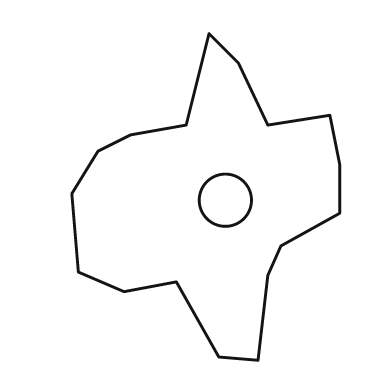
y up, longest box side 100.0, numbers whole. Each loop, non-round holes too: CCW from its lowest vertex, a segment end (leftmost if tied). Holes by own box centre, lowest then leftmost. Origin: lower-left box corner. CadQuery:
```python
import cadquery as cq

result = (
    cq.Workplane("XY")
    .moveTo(57.0, 0.0)
    .lineTo(60.0, 26.0)
    .lineTo(64.0, 35.0)
    .lineTo(82.0, 45.0)
    .lineTo(82.0, 60.0)
    .lineTo(79.0, 75.0)
    .lineTo(60.0, 72.0)
    .lineTo(51.0, 91.0)
    .lineTo(42.0, 100.0)
    .lineTo(35.0, 72.0)
    .lineTo(18.0, 69.0)
    .lineTo(8.0, 64.0)
    .lineTo(0.0, 51.0)
    .lineTo(2.0, 27.0)
    .lineTo(16.0, 21.0)
    .lineTo(32.0, 24.0)
    .lineTo(45.0, 1.0)
    .close()
    .moveTo(47.0, 49.0)
    .circle(8.0)
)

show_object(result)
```